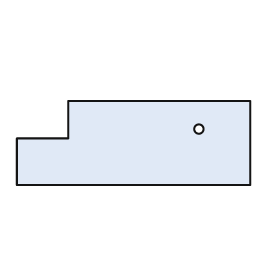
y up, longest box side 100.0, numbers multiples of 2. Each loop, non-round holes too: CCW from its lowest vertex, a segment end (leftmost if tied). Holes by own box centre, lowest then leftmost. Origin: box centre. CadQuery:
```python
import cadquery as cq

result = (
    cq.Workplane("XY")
    .moveTo(-50.0, -18.0)
    .lineTo(50.0, -18.0)
    .lineTo(50.0, 18.0)
    .lineTo(-28.0, 18.0)
    .lineTo(-28.0, 2.0)
    .lineTo(-50.0, 2.0)
    .close()
    .moveTo(28.0, 6.0)
    .circle(2.0)
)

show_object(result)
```